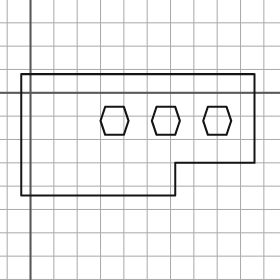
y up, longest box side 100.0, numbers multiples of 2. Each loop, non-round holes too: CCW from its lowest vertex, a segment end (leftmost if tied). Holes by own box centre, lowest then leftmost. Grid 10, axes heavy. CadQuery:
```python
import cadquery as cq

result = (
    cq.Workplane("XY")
    .moveTo(-4.0, -44.0)
    .lineTo(62.0, -44.0)
    .lineTo(62.0, -30.0)
    .lineTo(96.0, -30.0)
    .lineTo(96.0, 8.0)
    .lineTo(-4.0, 8.0)
    .close()
    .moveTo(32.0, -18.0)
    .lineTo(40.0, -18.0)
    .lineTo(42.0, -12.0)
    .lineTo(40.0, -6.0)
    .lineTo(32.0, -6.0)
    .lineTo(30.0, -12.0)
    .close()
    .moveTo(54.0, -18.0)
    .lineTo(62.0, -18.0)
    .lineTo(64.0, -12.0)
    .lineTo(62.0, -6.0)
    .lineTo(54.0, -6.0)
    .lineTo(52.0, -12.0)
    .close()
    .moveTo(76.0, -18.0)
    .lineTo(84.0, -18.0)
    .lineTo(86.0, -12.0)
    .lineTo(84.0, -6.0)
    .lineTo(76.0, -6.0)
    .lineTo(74.0, -12.0)
    .close()
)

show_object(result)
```